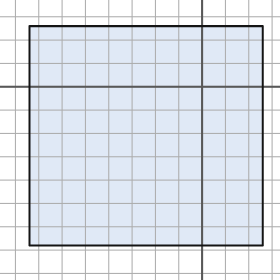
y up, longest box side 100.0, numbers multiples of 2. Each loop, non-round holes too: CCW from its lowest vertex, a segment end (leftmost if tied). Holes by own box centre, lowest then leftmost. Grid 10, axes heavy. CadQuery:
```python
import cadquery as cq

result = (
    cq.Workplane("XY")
    .moveTo(-74.0, -68.0)
    .lineTo(26.0, -68.0)
    .lineTo(26.0, 26.0)
    .lineTo(-74.0, 26.0)
    .close()
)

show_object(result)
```